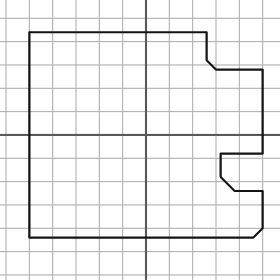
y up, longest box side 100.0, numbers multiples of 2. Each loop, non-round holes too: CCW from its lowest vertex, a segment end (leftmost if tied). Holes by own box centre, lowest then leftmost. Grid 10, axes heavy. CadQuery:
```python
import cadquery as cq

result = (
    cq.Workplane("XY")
    .moveTo(-50.0, -44.0)
    .lineTo(46.0, -44.0)
    .lineTo(50.0, -40.0)
    .lineTo(50.0, -24.0)
    .lineTo(38.0, -24.0)
    .lineTo(32.0, -18.0)
    .lineTo(32.0, -8.0)
    .lineTo(50.0, -8.0)
    .lineTo(50.0, 28.0)
    .lineTo(30.0, 28.0)
    .lineTo(26.0, 32.0)
    .lineTo(26.0, 44.0)
    .lineTo(-50.0, 44.0)
    .close()
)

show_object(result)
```